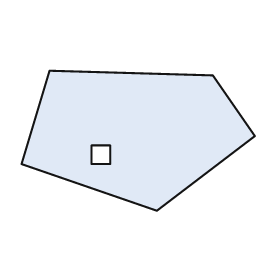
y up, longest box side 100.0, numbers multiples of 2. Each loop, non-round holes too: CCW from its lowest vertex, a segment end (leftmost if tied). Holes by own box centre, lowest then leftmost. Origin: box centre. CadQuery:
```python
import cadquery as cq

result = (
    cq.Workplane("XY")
    .moveTo(8.0, -30.0)
    .lineTo(50.0, 2.0)
    .lineTo(32.0, 28.0)
    .lineTo(-38.0, 30.0)
    .lineTo(-50.0, -10.0)
    .close()
    .moveTo(-20.0, -10.0)
    .lineTo(-12.0, -10.0)
    .lineTo(-12.0, -2.0)
    .lineTo(-20.0, -2.0)
    .close()
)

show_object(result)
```